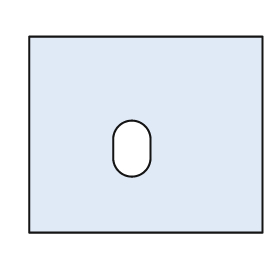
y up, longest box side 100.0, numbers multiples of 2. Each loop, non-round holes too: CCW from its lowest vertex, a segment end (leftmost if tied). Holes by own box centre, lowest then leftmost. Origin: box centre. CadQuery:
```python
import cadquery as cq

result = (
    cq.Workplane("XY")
    .moveTo(-50.0, -42.0)
    .lineTo(50.0, -42.0)
    .lineTo(50.0, 42.0)
    .lineTo(-50.0, 42.0)
    .close()
    .moveTo(-14.0, -10.0)
    .threePointArc((-6.0, -18.0), (2.0, -10.0))
    .lineTo(2.0, -2.0)
    .threePointArc((-6.0, 6.0), (-14.0, -2.0))
    .close()
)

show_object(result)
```